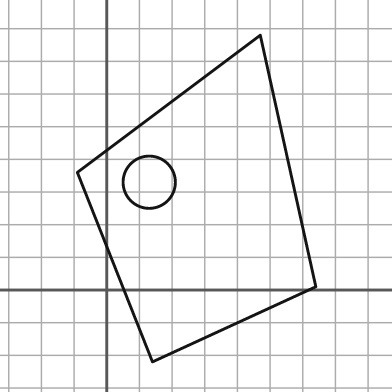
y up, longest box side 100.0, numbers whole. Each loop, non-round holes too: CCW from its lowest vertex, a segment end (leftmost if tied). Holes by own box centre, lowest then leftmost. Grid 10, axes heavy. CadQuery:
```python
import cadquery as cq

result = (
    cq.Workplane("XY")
    .moveTo(14.0, -22.0)
    .lineTo(64.0, 1.0)
    .lineTo(47.0, 78.0)
    .lineTo(-9.0, 36.0)
    .close()
    .moveTo(13.0, 33.0)
    .circle(8.0)
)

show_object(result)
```